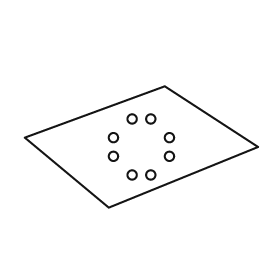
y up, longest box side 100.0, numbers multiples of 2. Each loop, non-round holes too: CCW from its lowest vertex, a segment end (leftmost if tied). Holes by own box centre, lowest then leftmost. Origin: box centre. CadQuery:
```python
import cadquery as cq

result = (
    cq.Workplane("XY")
    .moveTo(-14.0, -26.0)
    .lineTo(50.0, 0.0)
    .lineTo(10.0, 26.0)
    .lineTo(-50.0, 4.0)
    .close()
    .moveTo(-4.0, -12.0)
    .circle(2.0)
    .moveTo(4.0, -12.0)
    .circle(2.0)
    .moveTo(-12.0, -4.0)
    .circle(2.0)
    .moveTo(12.0, -4.0)
    .circle(2.0)
    .moveTo(-12.0, 4.0)
    .circle(2.0)
    .moveTo(12.0, 4.0)
    .circle(2.0)
    .moveTo(-4.0, 12.0)
    .circle(2.0)
    .moveTo(4.0, 12.0)
    .circle(2.0)
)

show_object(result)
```